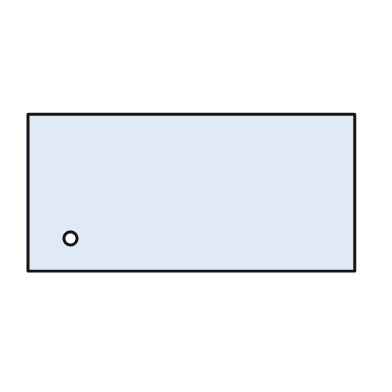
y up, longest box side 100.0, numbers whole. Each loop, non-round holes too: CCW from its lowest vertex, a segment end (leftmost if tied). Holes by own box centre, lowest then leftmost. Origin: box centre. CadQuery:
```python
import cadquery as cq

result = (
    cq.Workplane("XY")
    .moveTo(-50.0, -24.0)
    .lineTo(50.0, -24.0)
    .lineTo(50.0, 24.0)
    .lineTo(-50.0, 24.0)
    .close()
    .moveTo(-37.0, -14.0)
    .circle(2.0)
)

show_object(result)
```